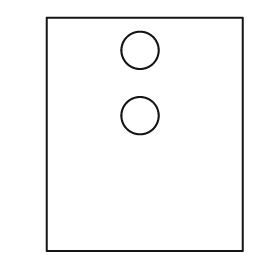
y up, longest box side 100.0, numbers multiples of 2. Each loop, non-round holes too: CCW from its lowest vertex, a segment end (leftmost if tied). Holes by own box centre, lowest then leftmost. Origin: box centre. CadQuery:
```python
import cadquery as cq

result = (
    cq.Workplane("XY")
    .moveTo(-42.0, -50.0)
    .lineTo(42.0, -50.0)
    .lineTo(42.0, 50.0)
    .lineTo(-42.0, 50.0)
    .close()
    .moveTo(-2.0, 8.0)
    .circle(8.0)
    .moveTo(-2.0, 36.0)
    .circle(8.0)
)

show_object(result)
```